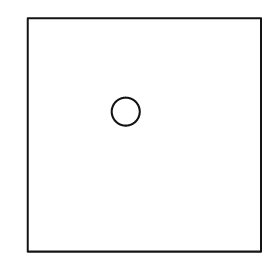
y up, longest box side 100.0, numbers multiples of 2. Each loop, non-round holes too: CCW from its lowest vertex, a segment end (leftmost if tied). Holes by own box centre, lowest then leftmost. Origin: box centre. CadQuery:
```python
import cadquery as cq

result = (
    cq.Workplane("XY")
    .moveTo(-50.0, -50.0)
    .lineTo(50.0, -50.0)
    .lineTo(50.0, 50.0)
    .lineTo(-50.0, 50.0)
    .close()
    .moveTo(-8.0, 10.0)
    .circle(6.0)
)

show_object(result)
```